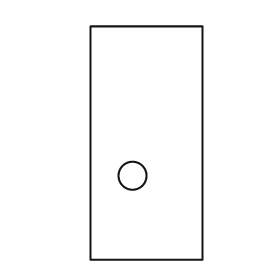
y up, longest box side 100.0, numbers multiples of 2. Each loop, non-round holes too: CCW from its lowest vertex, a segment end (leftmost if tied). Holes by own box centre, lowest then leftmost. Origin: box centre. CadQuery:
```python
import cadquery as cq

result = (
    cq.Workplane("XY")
    .moveTo(-24.0, -50.0)
    .lineTo(24.0, -50.0)
    .lineTo(24.0, 50.0)
    .lineTo(-24.0, 50.0)
    .close()
    .moveTo(-6.0, -14.0)
    .circle(6.0)
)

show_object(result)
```